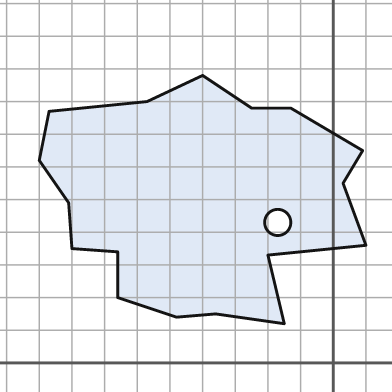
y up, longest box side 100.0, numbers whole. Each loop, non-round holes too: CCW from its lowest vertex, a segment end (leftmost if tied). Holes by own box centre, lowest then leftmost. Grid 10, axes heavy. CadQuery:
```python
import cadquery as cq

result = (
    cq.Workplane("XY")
    .moveTo(-15.0, 12.0)
    .lineTo(-20.0, 33.0)
    .lineTo(10.0, 36.0)
    .lineTo(3.0, 55.0)
    .lineTo(9.0, 65.0)
    .lineTo(-13.0, 78.0)
    .lineTo(-25.0, 78.0)
    .lineTo(-40.0, 88.0)
    .lineTo(-57.0, 80.0)
    .lineTo(-87.0, 77.0)
    .lineTo(-90.0, 62.0)
    .lineTo(-81.0, 49.0)
    .lineTo(-80.0, 35.0)
    .lineTo(-66.0, 34.0)
    .lineTo(-66.0, 20.0)
    .lineTo(-48.0, 14.0)
    .lineTo(-36.0, 15.0)
    .close()
    .moveTo(-17.0, 43.0)
    .circle(4.0)
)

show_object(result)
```